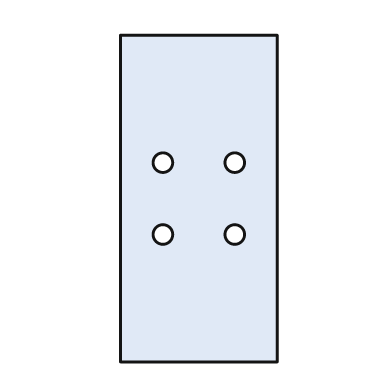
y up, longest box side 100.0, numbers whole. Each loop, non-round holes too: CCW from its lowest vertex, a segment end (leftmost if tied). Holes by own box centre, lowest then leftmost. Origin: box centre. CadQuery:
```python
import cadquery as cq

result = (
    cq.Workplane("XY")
    .moveTo(-24.0, -50.0)
    .lineTo(24.0, -50.0)
    .lineTo(24.0, 50.0)
    .lineTo(-24.0, 50.0)
    .close()
    .moveTo(-11.0, -11.0)
    .circle(3.0)
    .moveTo(11.0, -11.0)
    .circle(3.0)
    .moveTo(-11.0, 11.0)
    .circle(3.0)
    .moveTo(11.0, 11.0)
    .circle(3.0)
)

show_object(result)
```